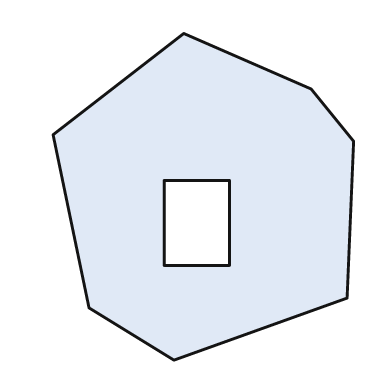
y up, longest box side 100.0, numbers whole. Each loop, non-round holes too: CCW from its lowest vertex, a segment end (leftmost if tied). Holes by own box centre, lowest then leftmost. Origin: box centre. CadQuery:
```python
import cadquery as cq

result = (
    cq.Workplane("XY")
    .moveTo(-9.0, -50.0)
    .lineTo(44.0, -31.0)
    .lineTo(46.0, 17.0)
    .lineTo(33.0, 33.0)
    .lineTo(-6.0, 50.0)
    .lineTo(-46.0, 19.0)
    .lineTo(-35.0, -34.0)
    .close()
    .moveTo(-12.0, -21.0)
    .lineTo(8.0, -21.0)
    .lineTo(8.0, 5.0)
    .lineTo(-12.0, 5.0)
    .close()
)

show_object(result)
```